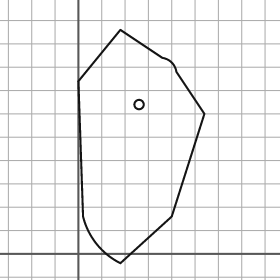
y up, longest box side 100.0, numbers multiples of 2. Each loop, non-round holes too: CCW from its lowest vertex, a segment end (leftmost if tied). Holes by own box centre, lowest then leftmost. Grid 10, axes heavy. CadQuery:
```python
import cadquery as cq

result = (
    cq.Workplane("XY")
    .moveTo(18.0, -4.0)
    .lineTo(40.0, 16.0)
    .lineTo(54.0, 60.0)
    .lineTo(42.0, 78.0)
    .threePointArc((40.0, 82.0), (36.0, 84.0))
    .lineTo(18.0, 96.0)
    .lineTo(0.0, 74.0)
    .lineTo(2.0, 16.0)
    .threePointArc((8.0, 4.0), (18.0, -4.0))
    .close()
    .moveTo(26.0, 64.0)
    .circle(2.0)
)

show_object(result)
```